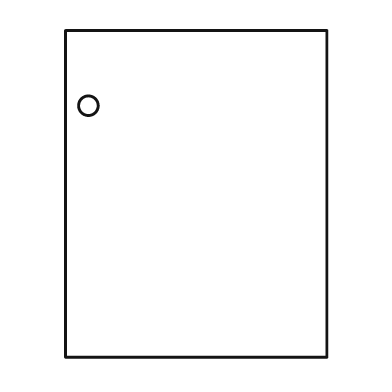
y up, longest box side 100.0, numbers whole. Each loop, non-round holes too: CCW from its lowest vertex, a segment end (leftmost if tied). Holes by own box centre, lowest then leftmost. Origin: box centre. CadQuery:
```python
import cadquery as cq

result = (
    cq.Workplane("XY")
    .moveTo(-40.0, -50.0)
    .lineTo(40.0, -50.0)
    .lineTo(40.0, 50.0)
    .lineTo(-40.0, 50.0)
    .close()
    .moveTo(-33.0, 27.0)
    .circle(3.0)
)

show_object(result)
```